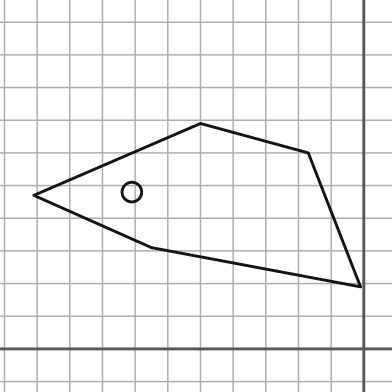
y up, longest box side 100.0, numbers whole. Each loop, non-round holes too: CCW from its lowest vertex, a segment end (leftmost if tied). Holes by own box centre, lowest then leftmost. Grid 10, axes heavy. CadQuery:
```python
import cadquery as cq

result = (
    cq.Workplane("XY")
    .moveTo(-1.0, 19.0)
    .lineTo(-17.0, 60.0)
    .lineTo(-50.0, 69.0)
    .lineTo(-101.0, 47.0)
    .lineTo(-65.0, 31.0)
    .close()
    .moveTo(-71.0, 48.0)
    .circle(3.0)
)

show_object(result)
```